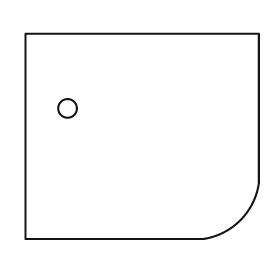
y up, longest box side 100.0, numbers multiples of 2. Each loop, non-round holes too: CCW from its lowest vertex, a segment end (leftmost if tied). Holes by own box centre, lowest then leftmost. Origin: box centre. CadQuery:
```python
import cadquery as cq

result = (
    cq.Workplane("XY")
    .moveTo(-50.0, -44.0)
    .lineTo(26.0, -44.0)
    .threePointArc((42.0, -36.0), (50.0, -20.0))
    .lineTo(50.0, 44.0)
    .lineTo(-50.0, 44.0)
    .close()
    .moveTo(-32.0, 12.0)
    .circle(4.0)
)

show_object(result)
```